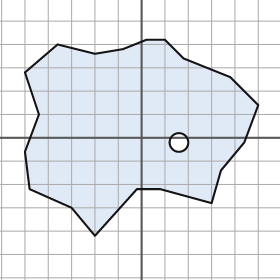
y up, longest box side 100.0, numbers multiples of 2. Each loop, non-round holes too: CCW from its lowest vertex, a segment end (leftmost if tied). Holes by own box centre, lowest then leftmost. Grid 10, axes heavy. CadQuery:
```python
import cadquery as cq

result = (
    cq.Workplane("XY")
    .moveTo(-20.0, -42.0)
    .lineTo(-2.0, -22.0)
    .lineTo(8.0, -22.0)
    .lineTo(30.0, -28.0)
    .lineTo(34.0, -14.0)
    .lineTo(44.0, -2.0)
    .lineTo(50.0, 14.0)
    .lineTo(38.0, 26.0)
    .lineTo(18.0, 34.0)
    .lineTo(10.0, 42.0)
    .lineTo(2.0, 42.0)
    .lineTo(-8.0, 38.0)
    .lineTo(-20.0, 36.0)
    .lineTo(-36.0, 40.0)
    .lineTo(-50.0, 28.0)
    .lineTo(-44.0, 10.0)
    .lineTo(-50.0, -6.0)
    .lineTo(-48.0, -22.0)
    .lineTo(-30.0, -30.0)
    .close()
    .moveTo(16.0, -2.0)
    .circle(4.0)
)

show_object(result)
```